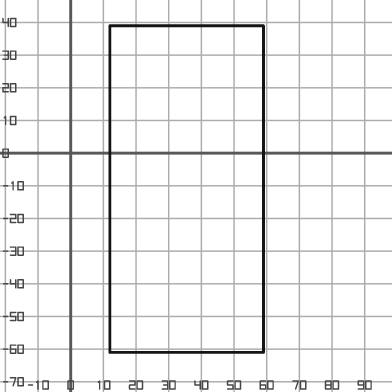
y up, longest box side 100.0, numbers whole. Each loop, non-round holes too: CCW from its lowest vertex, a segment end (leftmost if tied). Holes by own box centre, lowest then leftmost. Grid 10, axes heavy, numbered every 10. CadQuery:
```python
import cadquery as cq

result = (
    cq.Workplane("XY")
    .moveTo(12.0, -61.0)
    .lineTo(59.0, -61.0)
    .lineTo(59.0, 39.0)
    .lineTo(12.0, 39.0)
    .close()
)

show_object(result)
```